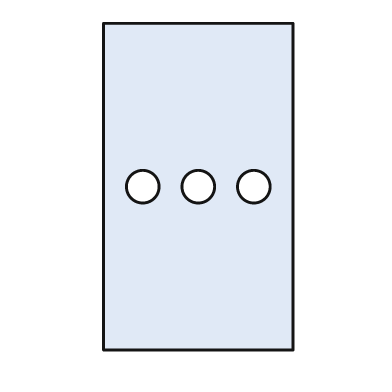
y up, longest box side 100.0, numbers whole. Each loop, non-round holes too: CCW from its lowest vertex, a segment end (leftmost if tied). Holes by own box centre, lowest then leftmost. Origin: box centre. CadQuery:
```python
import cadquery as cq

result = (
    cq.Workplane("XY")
    .moveTo(-29.0, -50.0)
    .lineTo(29.0, -50.0)
    .lineTo(29.0, 50.0)
    .lineTo(-29.0, 50.0)
    .close()
    .moveTo(-17.0, 0.0)
    .circle(5.0)
    .moveTo(0.0, 0.0)
    .circle(5.0)
    .moveTo(17.0, 0.0)
    .circle(5.0)
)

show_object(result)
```